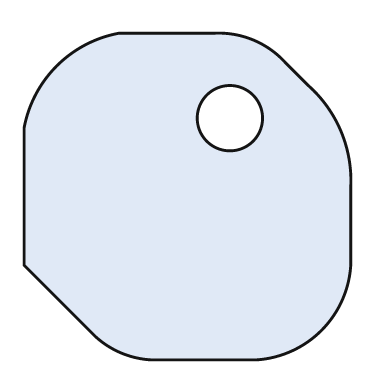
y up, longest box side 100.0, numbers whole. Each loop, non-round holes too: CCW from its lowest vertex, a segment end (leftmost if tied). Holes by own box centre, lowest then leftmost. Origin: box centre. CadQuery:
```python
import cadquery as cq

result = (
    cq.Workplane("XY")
    .moveTo(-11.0, -50.0)
    .lineTo(21.0, -50.0)
    .threePointArc((41.0, -41.0), (50.0, -21.0))
    .lineTo(50.0, 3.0)
    .threePointArc((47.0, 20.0), (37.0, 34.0))
    .lineTo(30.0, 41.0)
    .threePointArc((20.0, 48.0), (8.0, 50.0))
    .lineTo(-21.0, 50.0)
    .threePointArc((-40.0, 40.0), (-50.0, 21.0))
    .lineTo(-50.0, -21.0)
    .lineTo(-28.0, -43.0)
    .threePointArc((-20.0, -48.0), (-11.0, -50.0))
    .close()
    .moveTo(13.0, 24.0)
    .circle(10.0)
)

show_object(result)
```